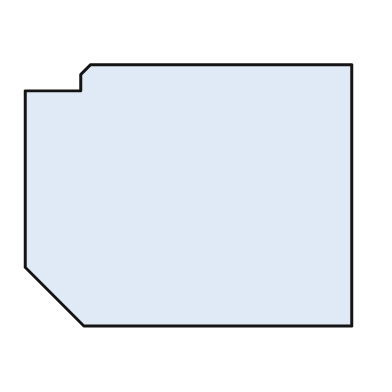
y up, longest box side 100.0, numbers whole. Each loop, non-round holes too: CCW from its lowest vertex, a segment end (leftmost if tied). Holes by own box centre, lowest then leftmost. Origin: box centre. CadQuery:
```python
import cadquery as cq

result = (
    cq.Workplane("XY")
    .moveTo(-32.0, -40.0)
    .lineTo(50.0, -40.0)
    .lineTo(50.0, 40.0)
    .lineTo(-30.0, 40.0)
    .lineTo(-33.0, 37.0)
    .lineTo(-33.0, 32.0)
    .lineTo(-50.0, 32.0)
    .lineTo(-50.0, -22.0)
    .close()
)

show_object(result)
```